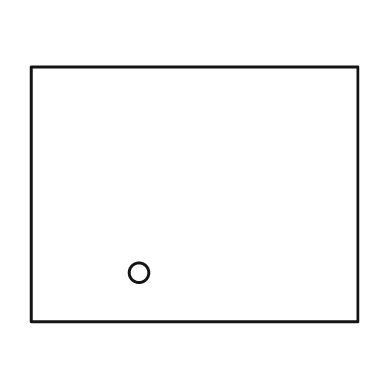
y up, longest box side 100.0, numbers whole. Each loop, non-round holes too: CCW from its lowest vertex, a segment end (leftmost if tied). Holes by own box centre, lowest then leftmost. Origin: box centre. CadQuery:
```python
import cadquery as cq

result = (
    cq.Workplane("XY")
    .moveTo(-50.0, -39.0)
    .lineTo(50.0, -39.0)
    .lineTo(50.0, 39.0)
    .lineTo(-50.0, 39.0)
    .close()
    .moveTo(-17.0, -24.0)
    .circle(3.0)
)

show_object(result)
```